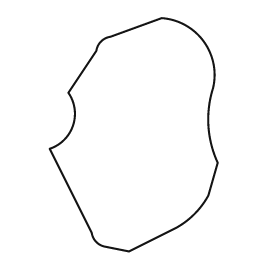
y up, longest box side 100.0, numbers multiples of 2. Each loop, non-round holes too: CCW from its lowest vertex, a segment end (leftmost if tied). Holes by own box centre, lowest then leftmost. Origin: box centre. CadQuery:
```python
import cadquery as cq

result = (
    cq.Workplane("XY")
    .moveTo(-2.0, -50.0)
    .lineTo(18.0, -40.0)
    .threePointArc((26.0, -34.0), (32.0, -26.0))
    .lineTo(36.0, -12.0)
    .threePointArc((32.0, 4.0), (34.0, 20.0))
    .threePointArc((30.0, 40.0), (12.0, 50.0))
    .lineTo(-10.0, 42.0)
    .threePointArc((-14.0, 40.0), (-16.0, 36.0))
    .lineTo(-28.0, 18.0)
    .threePointArc((-26.0, 4.0), (-36.0, -6.0))
    .lineTo(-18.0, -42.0)
    .threePointArc((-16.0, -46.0), (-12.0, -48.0))
    .close()
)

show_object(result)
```